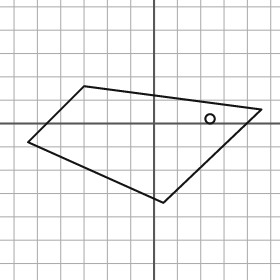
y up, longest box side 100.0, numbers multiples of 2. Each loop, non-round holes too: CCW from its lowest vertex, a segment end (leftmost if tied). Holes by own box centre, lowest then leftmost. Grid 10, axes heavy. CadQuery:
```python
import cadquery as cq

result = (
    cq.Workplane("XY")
    .moveTo(4.0, -34.0)
    .lineTo(46.0, 6.0)
    .lineTo(-30.0, 16.0)
    .lineTo(-54.0, -8.0)
    .close()
    .moveTo(24.0, 2.0)
    .circle(2.0)
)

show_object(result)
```